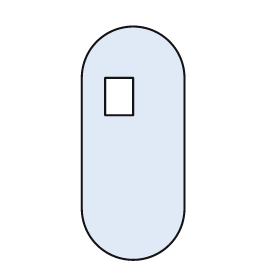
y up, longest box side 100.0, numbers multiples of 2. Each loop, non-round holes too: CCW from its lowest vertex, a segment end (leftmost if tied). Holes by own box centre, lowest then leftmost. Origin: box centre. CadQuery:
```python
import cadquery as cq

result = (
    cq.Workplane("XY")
    .moveTo(-22.0, -28.0)
    .threePointArc((0.0, -50.0), (22.0, -28.0))
    .lineTo(22.0, 28.0)
    .threePointArc((0.0, 50.0), (-22.0, 28.0))
    .close()
    .moveTo(-12.0, 12.0)
    .lineTo(0.0, 12.0)
    .lineTo(0.0, 28.0)
    .lineTo(-12.0, 28.0)
    .close()
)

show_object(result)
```